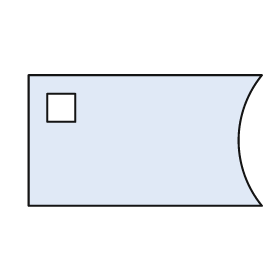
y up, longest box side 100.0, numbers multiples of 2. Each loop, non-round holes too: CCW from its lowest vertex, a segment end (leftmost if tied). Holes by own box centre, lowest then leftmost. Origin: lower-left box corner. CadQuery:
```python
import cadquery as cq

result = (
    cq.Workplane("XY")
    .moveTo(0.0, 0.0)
    .lineTo(100.0, 0.0)
    .threePointArc((90.0, 28.0), (100.0, 56.0))
    .lineTo(0.0, 56.0)
    .close()
    .moveTo(8.0, 36.0)
    .lineTo(20.0, 36.0)
    .lineTo(20.0, 48.0)
    .lineTo(8.0, 48.0)
    .close()
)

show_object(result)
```